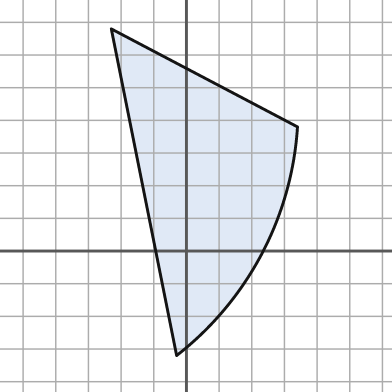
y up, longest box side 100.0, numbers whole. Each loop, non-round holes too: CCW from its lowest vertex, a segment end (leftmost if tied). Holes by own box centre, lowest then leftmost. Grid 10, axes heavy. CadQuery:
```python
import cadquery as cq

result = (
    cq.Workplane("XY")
    .moveTo(-3.0, -32.0)
    .threePointArc((23.0, -1.0), (34.0, 38.0))
    .lineTo(-23.0, 68.0)
    .close()
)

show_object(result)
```